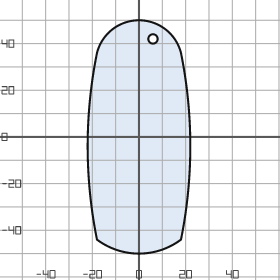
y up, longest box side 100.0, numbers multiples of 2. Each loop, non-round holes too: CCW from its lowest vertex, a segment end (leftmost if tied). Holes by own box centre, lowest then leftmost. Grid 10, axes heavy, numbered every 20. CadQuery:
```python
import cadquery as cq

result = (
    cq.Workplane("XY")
    .moveTo(-18.0, -44.0)
    .threePointArc((0.0, -50.0), (18.0, -44.0))
    .threePointArc((22.0, -4.0), (18.0, 36.0))
    .threePointArc((0.0, 50.0), (-18.0, 36.0))
    .threePointArc((-22.0, -4.0), (-18.0, -44.0))
    .close()
    .moveTo(6.0, 42.0)
    .circle(2.0)
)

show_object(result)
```